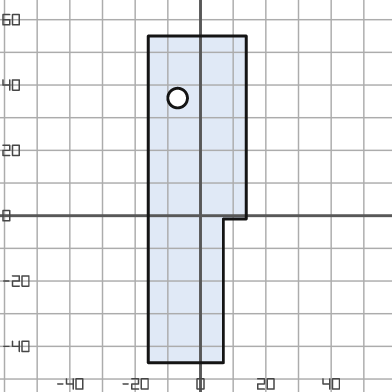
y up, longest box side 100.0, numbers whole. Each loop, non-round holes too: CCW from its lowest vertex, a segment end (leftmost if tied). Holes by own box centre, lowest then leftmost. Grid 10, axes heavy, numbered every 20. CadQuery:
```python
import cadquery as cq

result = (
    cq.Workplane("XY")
    .moveTo(-16.0, -45.0)
    .lineTo(7.0, -45.0)
    .lineTo(7.0, -1.0)
    .lineTo(14.0, -1.0)
    .lineTo(14.0, 55.0)
    .lineTo(-16.0, 55.0)
    .close()
    .moveTo(-7.0, 36.0)
    .circle(3.0)
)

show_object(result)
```